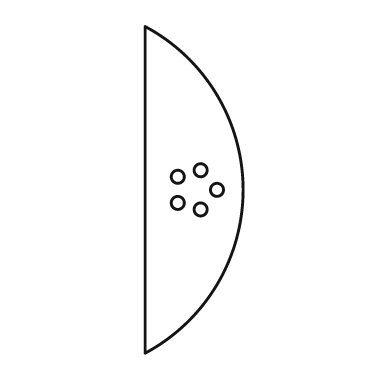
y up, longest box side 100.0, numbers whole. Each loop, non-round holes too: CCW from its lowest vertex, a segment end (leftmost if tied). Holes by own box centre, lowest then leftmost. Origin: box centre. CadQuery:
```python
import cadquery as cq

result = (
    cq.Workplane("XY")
    .moveTo(-15.0, -50.0)
    .threePointArc((15.0, 0.0), (-15.0, 50.0))
    .close()
    .moveTo(2.0, -6.0)
    .circle(2.0)
    .moveTo(-5.0, -4.0)
    .circle(2.0)
    .moveTo(7.0, 0.0)
    .circle(2.0)
    .moveTo(-5.0, 4.0)
    .circle(2.0)
    .moveTo(2.0, 6.0)
    .circle(2.0)
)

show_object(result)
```